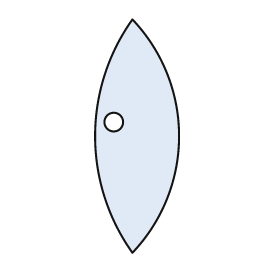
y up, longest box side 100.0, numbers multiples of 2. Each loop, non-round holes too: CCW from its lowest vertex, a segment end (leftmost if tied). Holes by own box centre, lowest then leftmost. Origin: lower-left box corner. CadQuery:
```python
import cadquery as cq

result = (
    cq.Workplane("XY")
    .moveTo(16.0, 0.0)
    .threePointArc((36.0, 50.0), (16.0, 100.0))
    .threePointArc((0.0, 50.0), (16.0, 0.0))
    .close()
    .moveTo(8.0, 56.0)
    .circle(4.0)
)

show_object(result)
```